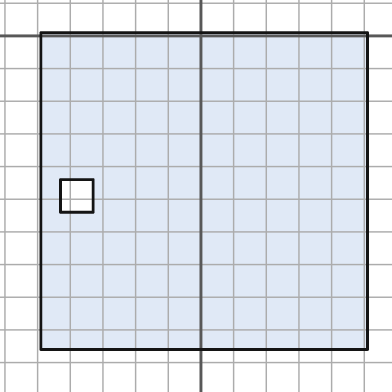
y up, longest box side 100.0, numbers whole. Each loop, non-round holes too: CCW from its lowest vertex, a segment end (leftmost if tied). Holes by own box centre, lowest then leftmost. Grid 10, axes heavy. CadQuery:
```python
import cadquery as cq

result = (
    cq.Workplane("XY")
    .moveTo(-49.0, -96.0)
    .lineTo(51.0, -96.0)
    .lineTo(51.0, 1.0)
    .lineTo(-49.0, 1.0)
    .close()
    .moveTo(-43.0, -54.0)
    .lineTo(-33.0, -54.0)
    .lineTo(-33.0, -44.0)
    .lineTo(-43.0, -44.0)
    .close()
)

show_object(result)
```